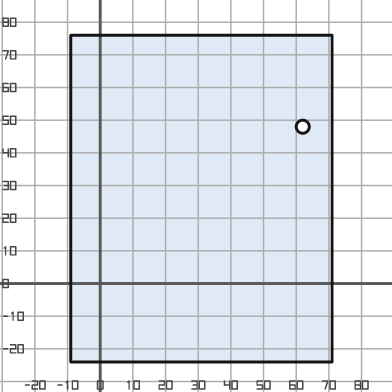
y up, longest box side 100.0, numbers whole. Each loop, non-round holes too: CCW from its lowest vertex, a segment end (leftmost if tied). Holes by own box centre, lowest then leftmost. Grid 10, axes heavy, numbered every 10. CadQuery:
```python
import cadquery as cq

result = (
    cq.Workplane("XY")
    .moveTo(-9.0, -24.0)
    .lineTo(71.0, -24.0)
    .lineTo(71.0, 76.0)
    .lineTo(-9.0, 76.0)
    .close()
    .moveTo(62.0, 48.0)
    .circle(2.0)
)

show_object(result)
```